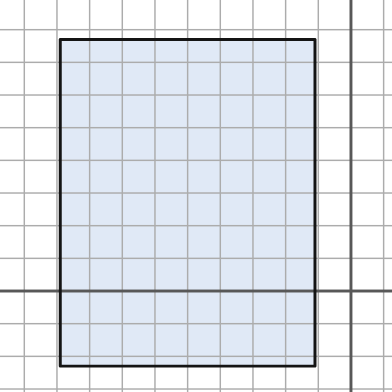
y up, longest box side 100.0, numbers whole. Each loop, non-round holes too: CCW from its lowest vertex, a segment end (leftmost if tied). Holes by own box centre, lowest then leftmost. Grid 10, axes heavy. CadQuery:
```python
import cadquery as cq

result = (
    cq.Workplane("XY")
    .moveTo(-89.0, -23.0)
    .lineTo(-11.0, -23.0)
    .lineTo(-11.0, 77.0)
    .lineTo(-89.0, 77.0)
    .close()
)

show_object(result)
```